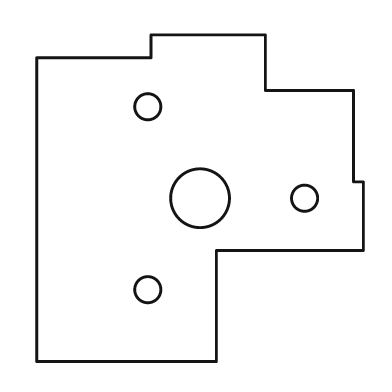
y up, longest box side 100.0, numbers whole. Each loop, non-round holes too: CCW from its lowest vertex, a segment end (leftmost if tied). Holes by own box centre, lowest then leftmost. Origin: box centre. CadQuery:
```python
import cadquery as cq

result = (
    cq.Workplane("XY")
    .moveTo(-50.0, -50.0)
    .lineTo(5.0, -50.0)
    .lineTo(5.0, -16.0)
    .lineTo(50.0, -16.0)
    .lineTo(50.0, 5.0)
    .lineTo(47.0, 5.0)
    .lineTo(47.0, 33.0)
    .lineTo(20.0, 33.0)
    .lineTo(20.0, 50.0)
    .lineTo(-15.0, 50.0)
    .lineTo(-15.0, 43.0)
    .lineTo(-50.0, 43.0)
    .close()
    .moveTo(-16.0, -28.0)
    .circle(4.0)
    .moveTo(0.0, 0.0)
    .circle(9.0)
    .moveTo(32.0, 0.0)
    .circle(4.0)
    .moveTo(-16.0, 28.0)
    .circle(4.0)
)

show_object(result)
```